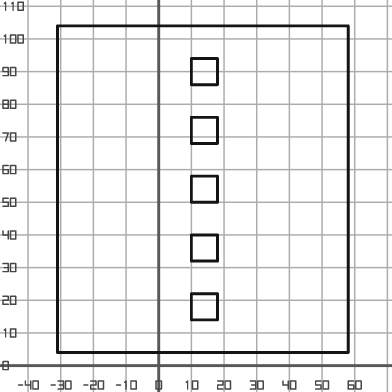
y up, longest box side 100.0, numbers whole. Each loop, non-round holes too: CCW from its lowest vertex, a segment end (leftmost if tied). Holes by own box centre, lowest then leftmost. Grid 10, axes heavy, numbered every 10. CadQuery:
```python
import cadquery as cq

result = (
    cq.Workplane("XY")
    .moveTo(-31.0, 4.0)
    .lineTo(58.0, 4.0)
    .lineTo(58.0, 104.0)
    .lineTo(-31.0, 104.0)
    .close()
    .moveTo(10.0, 14.0)
    .lineTo(18.0, 14.0)
    .lineTo(18.0, 22.0)
    .lineTo(10.0, 22.0)
    .close()
    .moveTo(10.0, 32.0)
    .lineTo(18.0, 32.0)
    .lineTo(18.0, 40.0)
    .lineTo(10.0, 40.0)
    .close()
    .moveTo(10.0, 50.0)
    .lineTo(18.0, 50.0)
    .lineTo(18.0, 58.0)
    .lineTo(10.0, 58.0)
    .close()
    .moveTo(10.0, 68.0)
    .lineTo(18.0, 68.0)
    .lineTo(18.0, 76.0)
    .lineTo(10.0, 76.0)
    .close()
    .moveTo(10.0, 86.0)
    .lineTo(18.0, 86.0)
    .lineTo(18.0, 94.0)
    .lineTo(10.0, 94.0)
    .close()
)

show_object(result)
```